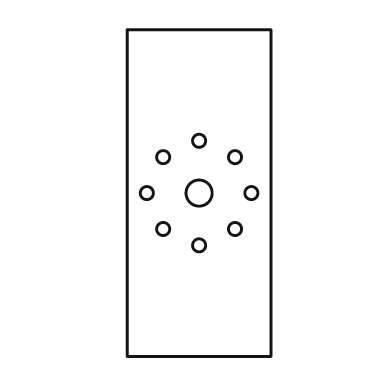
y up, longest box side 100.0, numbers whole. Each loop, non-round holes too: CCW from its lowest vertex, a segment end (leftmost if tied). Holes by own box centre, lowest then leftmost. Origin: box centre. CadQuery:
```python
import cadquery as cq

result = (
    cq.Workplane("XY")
    .moveTo(-22.0, -50.0)
    .lineTo(22.0, -50.0)
    .lineTo(22.0, 50.0)
    .lineTo(-22.0, 50.0)
    .close()
    .moveTo(0.0, -16.0)
    .circle(2.0)
    .moveTo(-11.0, -11.0)
    .circle(2.0)
    .moveTo(11.0, -11.0)
    .circle(2.0)
    .moveTo(-16.0, 0.0)
    .circle(2.0)
    .moveTo(0.0, 0.0)
    .circle(4.0)
    .moveTo(16.0, 0.0)
    .circle(2.0)
    .moveTo(-11.0, 11.0)
    .circle(2.0)
    .moveTo(11.0, 11.0)
    .circle(2.0)
    .moveTo(0.0, 16.0)
    .circle(2.0)
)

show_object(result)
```